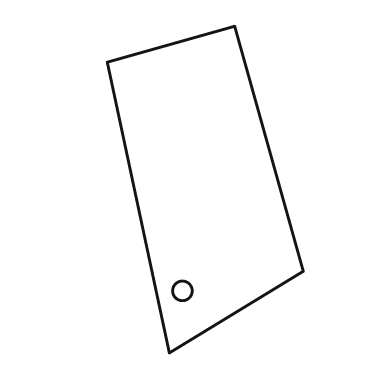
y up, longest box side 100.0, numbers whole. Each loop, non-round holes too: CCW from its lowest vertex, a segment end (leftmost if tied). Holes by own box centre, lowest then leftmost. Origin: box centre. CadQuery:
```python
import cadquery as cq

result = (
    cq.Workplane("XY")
    .moveTo(-11.0, -50.0)
    .lineTo(30.0, -25.0)
    .lineTo(9.0, 50.0)
    .lineTo(-30.0, 39.0)
    .close()
    .moveTo(-7.0, -31.0)
    .circle(3.0)
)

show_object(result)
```